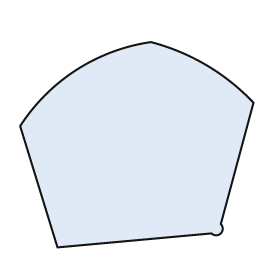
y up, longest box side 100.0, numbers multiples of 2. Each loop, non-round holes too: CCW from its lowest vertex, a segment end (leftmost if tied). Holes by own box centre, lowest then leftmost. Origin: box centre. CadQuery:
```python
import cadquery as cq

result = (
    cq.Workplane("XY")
    .moveTo(-34.0, -44.0)
    .lineTo(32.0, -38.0)
    .threePointArc((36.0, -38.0), (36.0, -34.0))
    .lineTo(50.0, 18.0)
    .threePointArc((30.0, 34.0), (6.0, 44.0))
    .threePointArc((-26.0, 32.0), (-50.0, 8.0))
    .close()
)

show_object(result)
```